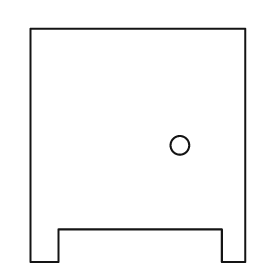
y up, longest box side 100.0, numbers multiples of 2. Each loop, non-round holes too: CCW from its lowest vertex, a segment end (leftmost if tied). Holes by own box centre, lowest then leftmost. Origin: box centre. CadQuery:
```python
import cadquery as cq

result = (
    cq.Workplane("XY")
    .moveTo(-46.0, -50.0)
    .lineTo(-34.0, -50.0)
    .lineTo(-34.0, -36.0)
    .lineTo(36.0, -36.0)
    .lineTo(36.0, -50.0)
    .lineTo(46.0, -50.0)
    .lineTo(46.0, 50.0)
    .lineTo(-46.0, 50.0)
    .close()
    .moveTo(18.0, 0.0)
    .circle(4.0)
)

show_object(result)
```